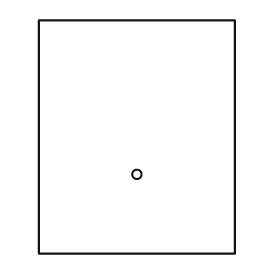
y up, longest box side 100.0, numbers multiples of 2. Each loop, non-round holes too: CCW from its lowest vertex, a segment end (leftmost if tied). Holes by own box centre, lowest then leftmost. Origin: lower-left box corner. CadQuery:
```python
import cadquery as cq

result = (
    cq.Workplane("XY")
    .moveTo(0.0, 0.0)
    .lineTo(84.0, 0.0)
    .lineTo(84.0, 100.0)
    .lineTo(0.0, 100.0)
    .close()
    .moveTo(42.0, 34.0)
    .circle(2.0)
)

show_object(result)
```